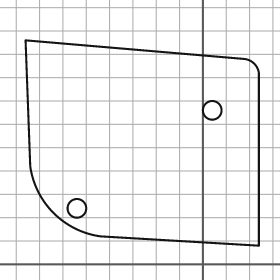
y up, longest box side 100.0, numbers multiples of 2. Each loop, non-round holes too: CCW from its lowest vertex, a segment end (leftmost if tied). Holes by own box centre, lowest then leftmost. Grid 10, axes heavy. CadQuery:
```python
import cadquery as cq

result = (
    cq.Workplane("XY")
    .moveTo(24.0, 8.0)
    .lineTo(24.0, 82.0)
    .threePointArc((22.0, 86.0), (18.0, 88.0))
    .lineTo(-76.0, 96.0)
    .lineTo(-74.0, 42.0)
    .threePointArc((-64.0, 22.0), (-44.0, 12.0))
    .close()
    .moveTo(-54.0, 24.0)
    .circle(4.0)
    .moveTo(4.0, 66.0)
    .circle(4.0)
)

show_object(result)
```